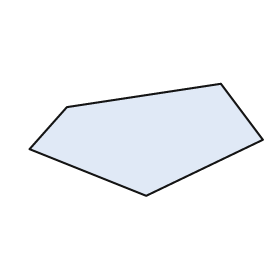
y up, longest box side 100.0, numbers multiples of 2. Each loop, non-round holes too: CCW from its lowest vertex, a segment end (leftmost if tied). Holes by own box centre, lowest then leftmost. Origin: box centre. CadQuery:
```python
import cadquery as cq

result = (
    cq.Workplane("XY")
    .moveTo(0.0, -24.0)
    .lineTo(50.0, 0.0)
    .lineTo(32.0, 24.0)
    .lineTo(-34.0, 14.0)
    .lineTo(-50.0, -4.0)
    .close()
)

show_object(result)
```